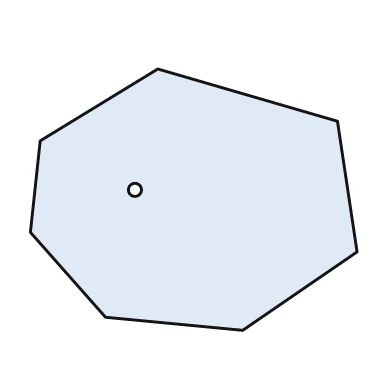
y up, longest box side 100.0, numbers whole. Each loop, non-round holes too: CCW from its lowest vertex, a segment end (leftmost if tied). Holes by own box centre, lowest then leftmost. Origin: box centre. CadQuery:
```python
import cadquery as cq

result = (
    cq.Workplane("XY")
    .moveTo(15.0, -40.0)
    .lineTo(50.0, -16.0)
    .lineTo(44.0, 24.0)
    .lineTo(-11.0, 40.0)
    .lineTo(-47.0, 18.0)
    .lineTo(-50.0, -10.0)
    .lineTo(-27.0, -36.0)
    .close()
    .moveTo(-18.0, 3.0)
    .circle(2.0)
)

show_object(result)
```